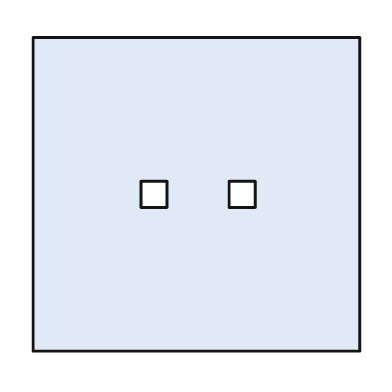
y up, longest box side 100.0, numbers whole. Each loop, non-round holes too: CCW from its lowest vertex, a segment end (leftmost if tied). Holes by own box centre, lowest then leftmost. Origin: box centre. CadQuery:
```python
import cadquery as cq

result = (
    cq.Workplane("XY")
    .moveTo(-50.0, -48.0)
    .lineTo(50.0, -48.0)
    .lineTo(50.0, 48.0)
    .lineTo(-50.0, 48.0)
    .close()
    .moveTo(-17.0, -4.0)
    .lineTo(-9.0, -4.0)
    .lineTo(-9.0, 4.0)
    .lineTo(-17.0, 4.0)
    .close()
    .moveTo(10.0, -4.0)
    .lineTo(18.0, -4.0)
    .lineTo(18.0, 4.0)
    .lineTo(10.0, 4.0)
    .close()
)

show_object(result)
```